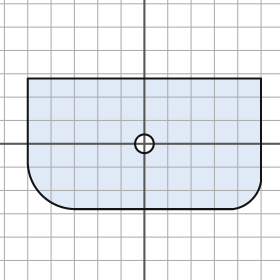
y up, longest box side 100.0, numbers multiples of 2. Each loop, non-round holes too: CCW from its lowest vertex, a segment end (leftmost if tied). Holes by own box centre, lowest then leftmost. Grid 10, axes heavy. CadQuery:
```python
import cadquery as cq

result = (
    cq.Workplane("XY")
    .moveTo(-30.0, -28.0)
    .lineTo(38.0, -28.0)
    .threePointArc((46.0, -24.0), (50.0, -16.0))
    .lineTo(50.0, 28.0)
    .lineTo(-50.0, 28.0)
    .lineTo(-50.0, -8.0)
    .threePointArc((-44.0, -22.0), (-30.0, -28.0))
    .close()
    .moveTo(0.0, 0.0)
    .circle(4.0)
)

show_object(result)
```